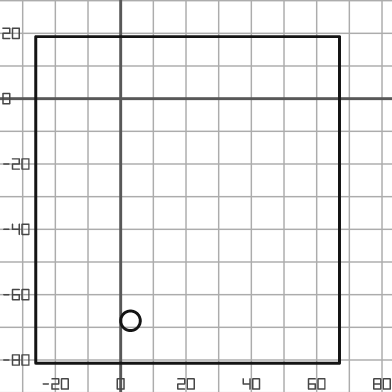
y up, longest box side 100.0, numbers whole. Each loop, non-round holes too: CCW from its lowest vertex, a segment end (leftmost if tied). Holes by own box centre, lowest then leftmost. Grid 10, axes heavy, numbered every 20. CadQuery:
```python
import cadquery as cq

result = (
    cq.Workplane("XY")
    .moveTo(-26.0, -81.0)
    .lineTo(67.0, -81.0)
    .lineTo(67.0, 19.0)
    .lineTo(-26.0, 19.0)
    .close()
    .moveTo(3.0, -68.0)
    .circle(3.0)
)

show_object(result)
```